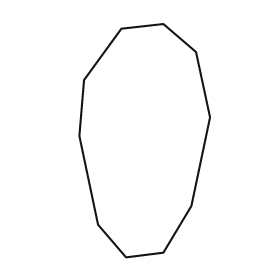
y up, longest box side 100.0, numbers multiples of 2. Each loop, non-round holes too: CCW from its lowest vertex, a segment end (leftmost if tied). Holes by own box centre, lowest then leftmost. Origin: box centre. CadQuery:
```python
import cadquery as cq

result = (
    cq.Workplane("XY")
    .moveTo(-8.0, -50.0)
    .lineTo(8.0, -48.0)
    .lineTo(20.0, -28.0)
    .lineTo(28.0, 10.0)
    .lineTo(22.0, 38.0)
    .lineTo(8.0, 50.0)
    .lineTo(-10.0, 48.0)
    .lineTo(-26.0, 26.0)
    .lineTo(-28.0, 2.0)
    .lineTo(-20.0, -36.0)
    .close()
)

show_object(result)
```